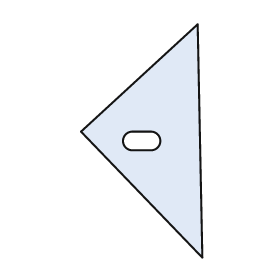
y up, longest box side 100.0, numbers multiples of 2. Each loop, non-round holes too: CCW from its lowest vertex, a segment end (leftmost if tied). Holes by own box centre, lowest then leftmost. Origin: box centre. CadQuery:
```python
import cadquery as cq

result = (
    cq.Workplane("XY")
    .moveTo(26.0, -50.0)
    .lineTo(24.0, 50.0)
    .lineTo(-26.0, 4.0)
    .close()
    .moveTo(-4.0, -4.0)
    .lineTo(4.0, -4.0)
    .threePointArc((8.0, 0.0), (4.0, 4.0))
    .lineTo(-4.0, 4.0)
    .threePointArc((-8.0, 0.0), (-4.0, -4.0))
    .close()
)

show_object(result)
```